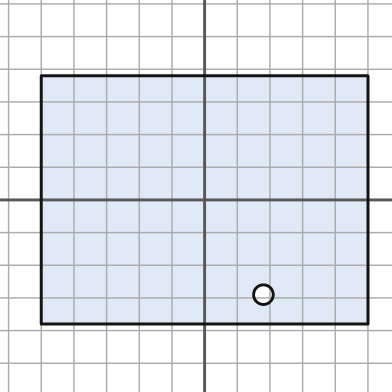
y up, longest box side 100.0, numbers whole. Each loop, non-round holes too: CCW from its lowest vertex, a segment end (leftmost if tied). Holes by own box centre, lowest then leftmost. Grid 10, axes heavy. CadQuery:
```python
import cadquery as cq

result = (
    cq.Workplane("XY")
    .moveTo(-50.0, -38.0)
    .lineTo(50.0, -38.0)
    .lineTo(50.0, 38.0)
    .lineTo(-50.0, 38.0)
    .close()
    .moveTo(18.0, -29.0)
    .circle(3.0)
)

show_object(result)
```